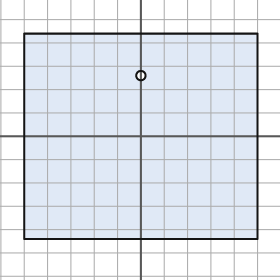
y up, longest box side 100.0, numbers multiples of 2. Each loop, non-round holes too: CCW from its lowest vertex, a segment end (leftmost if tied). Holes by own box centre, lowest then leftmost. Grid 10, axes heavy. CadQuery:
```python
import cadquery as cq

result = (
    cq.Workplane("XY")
    .moveTo(-50.0, -44.0)
    .lineTo(50.0, -44.0)
    .lineTo(50.0, 44.0)
    .lineTo(-50.0, 44.0)
    .close()
    .moveTo(0.0, 26.0)
    .circle(2.0)
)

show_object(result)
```